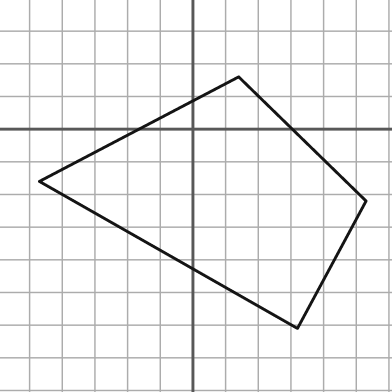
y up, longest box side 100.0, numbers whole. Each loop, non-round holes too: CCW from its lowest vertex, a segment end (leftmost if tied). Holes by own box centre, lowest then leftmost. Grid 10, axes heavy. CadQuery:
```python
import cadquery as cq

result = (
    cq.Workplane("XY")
    .moveTo(32.0, -61.0)
    .lineTo(53.0, -22.0)
    .lineTo(14.0, 16.0)
    .lineTo(-47.0, -16.0)
    .close()
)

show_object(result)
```